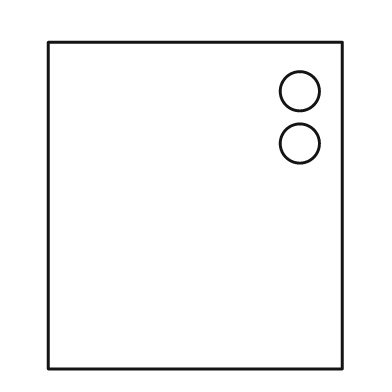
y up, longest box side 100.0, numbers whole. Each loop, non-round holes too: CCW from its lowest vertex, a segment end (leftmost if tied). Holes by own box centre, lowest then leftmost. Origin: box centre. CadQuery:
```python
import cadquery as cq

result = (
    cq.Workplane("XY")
    .moveTo(-45.0, -50.0)
    .lineTo(45.0, -50.0)
    .lineTo(45.0, 50.0)
    .lineTo(-45.0, 50.0)
    .close()
    .moveTo(32.0, 19.0)
    .circle(6.0)
    .moveTo(32.0, 35.0)
    .circle(6.0)
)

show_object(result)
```